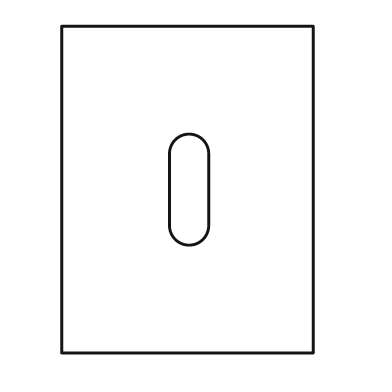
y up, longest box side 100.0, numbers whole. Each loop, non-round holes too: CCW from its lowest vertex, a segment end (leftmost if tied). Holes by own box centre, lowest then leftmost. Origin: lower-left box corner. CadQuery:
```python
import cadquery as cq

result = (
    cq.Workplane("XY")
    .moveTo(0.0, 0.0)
    .lineTo(77.0, 0.0)
    .lineTo(77.0, 100.0)
    .lineTo(0.0, 100.0)
    .close()
    .moveTo(33.0, 39.0)
    .threePointArc((39.0, 33.0), (45.0, 39.0))
    .lineTo(45.0, 61.0)
    .threePointArc((39.0, 67.0), (33.0, 61.0))
    .close()
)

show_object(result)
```